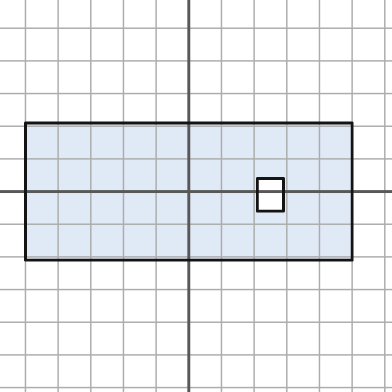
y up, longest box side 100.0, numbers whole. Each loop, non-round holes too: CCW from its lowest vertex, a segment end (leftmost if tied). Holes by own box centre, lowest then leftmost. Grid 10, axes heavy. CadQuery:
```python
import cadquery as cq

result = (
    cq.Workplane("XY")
    .moveTo(-50.0, -21.0)
    .lineTo(50.0, -21.0)
    .lineTo(50.0, 21.0)
    .lineTo(-50.0, 21.0)
    .close()
    .moveTo(21.0, -6.0)
    .lineTo(29.0, -6.0)
    .lineTo(29.0, 4.0)
    .lineTo(21.0, 4.0)
    .close()
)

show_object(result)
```